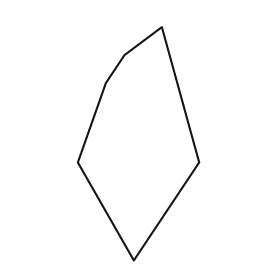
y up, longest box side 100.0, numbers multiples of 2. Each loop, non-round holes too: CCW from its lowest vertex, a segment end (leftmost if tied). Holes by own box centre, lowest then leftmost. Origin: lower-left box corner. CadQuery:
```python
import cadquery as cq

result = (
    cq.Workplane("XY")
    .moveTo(24.0, 0.0)
    .lineTo(52.0, 42.0)
    .lineTo(36.0, 100.0)
    .lineTo(20.0, 88.0)
    .lineTo(12.0, 76.0)
    .lineTo(0.0, 42.0)
    .close()
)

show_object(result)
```